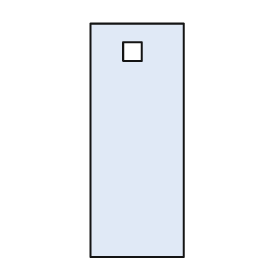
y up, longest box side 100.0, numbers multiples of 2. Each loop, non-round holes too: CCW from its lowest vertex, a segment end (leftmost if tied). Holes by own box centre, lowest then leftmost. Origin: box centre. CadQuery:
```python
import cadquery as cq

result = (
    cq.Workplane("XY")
    .moveTo(-20.0, -50.0)
    .lineTo(20.0, -50.0)
    .lineTo(20.0, 50.0)
    .lineTo(-20.0, 50.0)
    .close()
    .moveTo(-6.0, 34.0)
    .lineTo(2.0, 34.0)
    .lineTo(2.0, 42.0)
    .lineTo(-6.0, 42.0)
    .close()
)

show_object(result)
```